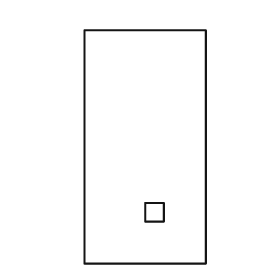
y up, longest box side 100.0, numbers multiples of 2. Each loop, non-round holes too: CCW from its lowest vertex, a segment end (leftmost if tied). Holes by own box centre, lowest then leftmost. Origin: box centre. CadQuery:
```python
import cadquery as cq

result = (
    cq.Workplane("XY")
    .moveTo(-26.0, -50.0)
    .lineTo(26.0, -50.0)
    .lineTo(26.0, 50.0)
    .lineTo(-26.0, 50.0)
    .close()
    .moveTo(0.0, -32.0)
    .lineTo(8.0, -32.0)
    .lineTo(8.0, -24.0)
    .lineTo(0.0, -24.0)
    .close()
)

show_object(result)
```